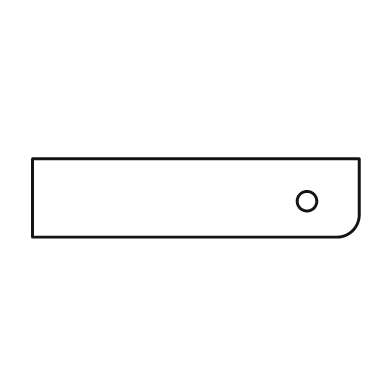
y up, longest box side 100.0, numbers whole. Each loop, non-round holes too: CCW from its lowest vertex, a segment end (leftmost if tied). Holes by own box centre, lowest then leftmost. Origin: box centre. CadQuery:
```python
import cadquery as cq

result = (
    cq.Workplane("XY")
    .moveTo(-50.0, -12.0)
    .lineTo(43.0, -12.0)
    .threePointArc((48.0, -10.0), (50.0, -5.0))
    .lineTo(50.0, 12.0)
    .lineTo(-50.0, 12.0)
    .close()
    .moveTo(34.0, -1.0)
    .circle(3.0)
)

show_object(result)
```